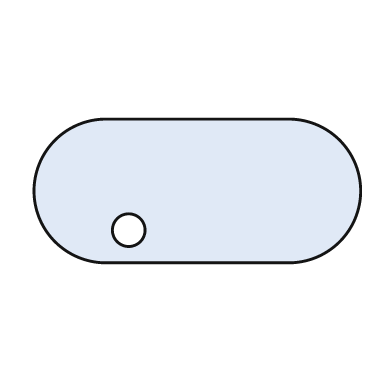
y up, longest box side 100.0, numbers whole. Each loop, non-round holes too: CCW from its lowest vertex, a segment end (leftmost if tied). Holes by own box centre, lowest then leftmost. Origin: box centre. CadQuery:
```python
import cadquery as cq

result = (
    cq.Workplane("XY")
    .moveTo(-28.0, -22.0)
    .lineTo(28.0, -22.0)
    .threePointArc((50.0, 0.0), (28.0, 22.0))
    .lineTo(-28.0, 22.0)
    .threePointArc((-50.0, 0.0), (-28.0, -22.0))
    .close()
    .moveTo(-21.0, -12.0)
    .circle(5.0)
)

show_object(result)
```